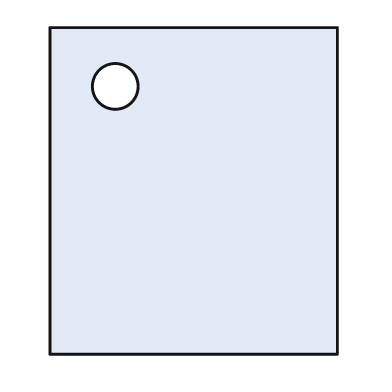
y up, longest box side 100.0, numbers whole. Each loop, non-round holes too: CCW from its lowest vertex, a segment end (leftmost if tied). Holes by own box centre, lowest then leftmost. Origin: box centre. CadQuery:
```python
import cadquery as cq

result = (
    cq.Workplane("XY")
    .moveTo(-44.0, -50.0)
    .lineTo(44.0, -50.0)
    .lineTo(44.0, 50.0)
    .lineTo(-44.0, 50.0)
    .close()
    .moveTo(-24.0, 32.0)
    .circle(7.0)
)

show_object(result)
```